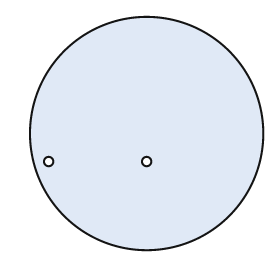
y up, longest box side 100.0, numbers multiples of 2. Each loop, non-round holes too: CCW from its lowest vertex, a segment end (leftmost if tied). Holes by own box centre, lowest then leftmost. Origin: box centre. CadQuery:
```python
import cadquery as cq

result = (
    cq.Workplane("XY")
    .moveTo(0.0, 0.0)
    .circle(50.0)
    .moveTo(-42.0, -12.0)
    .circle(2.0)
    .moveTo(0.0, -12.0)
    .circle(2.0)
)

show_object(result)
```